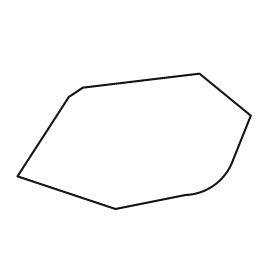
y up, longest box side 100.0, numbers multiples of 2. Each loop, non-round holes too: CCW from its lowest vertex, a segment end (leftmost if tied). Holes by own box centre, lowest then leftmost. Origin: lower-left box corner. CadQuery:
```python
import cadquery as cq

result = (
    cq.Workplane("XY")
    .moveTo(42.0, 0.0)
    .lineTo(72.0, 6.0)
    .threePointArc((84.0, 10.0), (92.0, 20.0))
    .lineTo(100.0, 40.0)
    .lineTo(78.0, 58.0)
    .lineTo(28.0, 52.0)
    .lineTo(22.0, 48.0)
    .lineTo(0.0, 14.0)
    .close()
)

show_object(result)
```